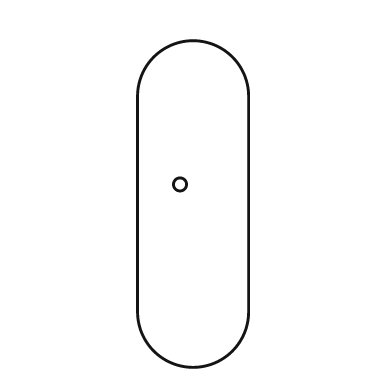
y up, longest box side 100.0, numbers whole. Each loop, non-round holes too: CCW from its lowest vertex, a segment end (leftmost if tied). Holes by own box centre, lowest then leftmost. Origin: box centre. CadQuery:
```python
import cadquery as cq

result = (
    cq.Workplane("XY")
    .moveTo(-17.0, -33.0)
    .threePointArc((0.0, -50.0), (17.0, -33.0))
    .lineTo(17.0, 33.0)
    .threePointArc((0.0, 50.0), (-17.0, 33.0))
    .close()
    .moveTo(-4.0, 6.0)
    .circle(2.0)
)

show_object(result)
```